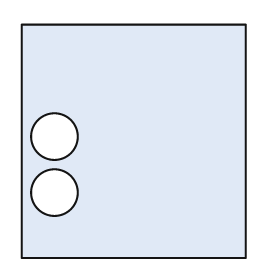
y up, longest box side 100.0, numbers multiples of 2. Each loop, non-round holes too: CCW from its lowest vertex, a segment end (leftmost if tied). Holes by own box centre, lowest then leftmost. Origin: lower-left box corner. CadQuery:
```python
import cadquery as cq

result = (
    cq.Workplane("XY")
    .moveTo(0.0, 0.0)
    .lineTo(96.0, 0.0)
    .lineTo(96.0, 100.0)
    .lineTo(0.0, 100.0)
    .close()
    .moveTo(14.0, 28.0)
    .circle(10.0)
    .moveTo(14.0, 52.0)
    .circle(10.0)
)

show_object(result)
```